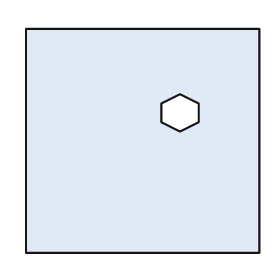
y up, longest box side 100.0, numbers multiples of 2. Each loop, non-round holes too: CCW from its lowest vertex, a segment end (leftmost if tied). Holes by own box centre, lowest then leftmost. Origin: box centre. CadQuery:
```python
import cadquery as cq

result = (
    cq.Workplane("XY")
    .moveTo(-50.0, -48.0)
    .lineTo(50.0, -48.0)
    .lineTo(50.0, 48.0)
    .lineTo(-50.0, 48.0)
    .close()
    .moveTo(16.0, 4.0)
    .lineTo(24.0, 8.0)
    .lineTo(24.0, 16.0)
    .lineTo(16.0, 20.0)
    .lineTo(8.0, 16.0)
    .lineTo(8.0, 8.0)
    .close()
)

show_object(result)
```